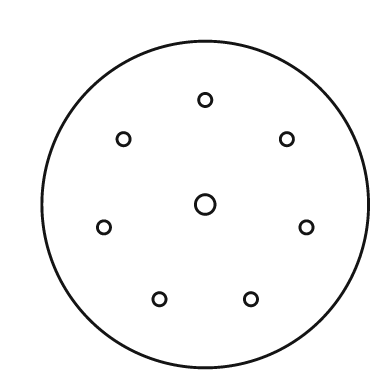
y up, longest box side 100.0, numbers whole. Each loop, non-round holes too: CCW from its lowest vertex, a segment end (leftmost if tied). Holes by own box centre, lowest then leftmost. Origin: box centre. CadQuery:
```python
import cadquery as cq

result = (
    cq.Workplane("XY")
    .moveTo(0.0, 0.0)
    .circle(50.0)
    .moveTo(-14.0, -29.0)
    .circle(2.0)
    .moveTo(14.0, -29.0)
    .circle(2.0)
    .moveTo(-31.0, -7.0)
    .circle(2.0)
    .moveTo(31.0, -7.0)
    .circle(2.0)
    .moveTo(0.0, 0.0)
    .circle(3.0)
    .moveTo(-25.0, 20.0)
    .circle(2.0)
    .moveTo(25.0, 20.0)
    .circle(2.0)
    .moveTo(0.0, 32.0)
    .circle(2.0)
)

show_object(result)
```